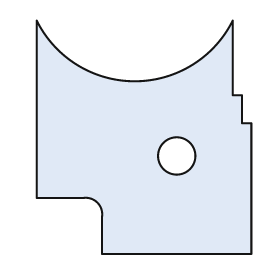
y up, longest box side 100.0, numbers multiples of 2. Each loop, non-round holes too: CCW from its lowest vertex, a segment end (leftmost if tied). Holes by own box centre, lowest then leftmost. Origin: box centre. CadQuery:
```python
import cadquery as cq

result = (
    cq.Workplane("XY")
    .moveTo(-18.0, -50.0)
    .lineTo(46.0, -50.0)
    .lineTo(46.0, 6.0)
    .lineTo(42.0, 6.0)
    .lineTo(42.0, 18.0)
    .lineTo(38.0, 18.0)
    .lineTo(38.0, 50.0)
    .threePointArc((-4.0, 24.0), (-46.0, 50.0))
    .lineTo(-46.0, -26.0)
    .lineTo(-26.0, -26.0)
    .threePointArc((-20.0, -28.0), (-18.0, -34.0))
    .close()
    .moveTo(14.0, -8.0)
    .circle(8.0)
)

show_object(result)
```